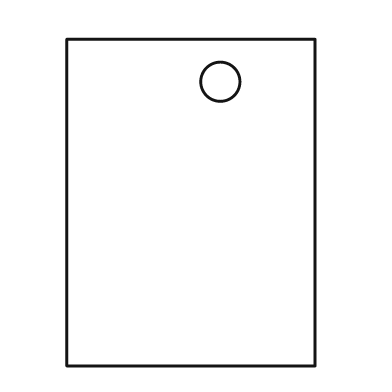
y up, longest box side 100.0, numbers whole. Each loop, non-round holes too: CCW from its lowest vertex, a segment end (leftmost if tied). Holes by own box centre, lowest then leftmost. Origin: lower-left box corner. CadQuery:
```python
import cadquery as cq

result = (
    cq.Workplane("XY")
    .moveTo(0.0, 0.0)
    .lineTo(76.0, 0.0)
    .lineTo(76.0, 100.0)
    .lineTo(0.0, 100.0)
    .close()
    .moveTo(47.0, 87.0)
    .circle(6.0)
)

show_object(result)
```